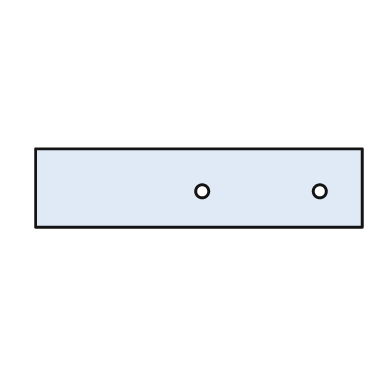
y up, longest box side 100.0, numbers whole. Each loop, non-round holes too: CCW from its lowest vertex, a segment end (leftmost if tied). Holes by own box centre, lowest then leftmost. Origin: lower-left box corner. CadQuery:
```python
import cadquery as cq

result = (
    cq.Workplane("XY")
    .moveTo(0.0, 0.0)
    .lineTo(100.0, 0.0)
    .lineTo(100.0, 24.0)
    .lineTo(0.0, 24.0)
    .close()
    .moveTo(51.0, 11.0)
    .circle(2.0)
    .moveTo(87.0, 11.0)
    .circle(2.0)
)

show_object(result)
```